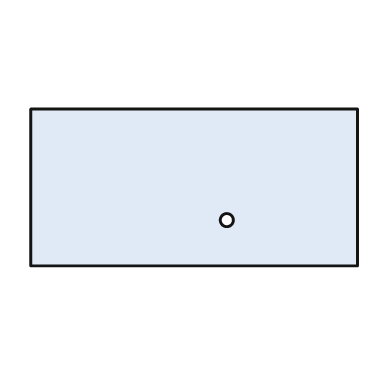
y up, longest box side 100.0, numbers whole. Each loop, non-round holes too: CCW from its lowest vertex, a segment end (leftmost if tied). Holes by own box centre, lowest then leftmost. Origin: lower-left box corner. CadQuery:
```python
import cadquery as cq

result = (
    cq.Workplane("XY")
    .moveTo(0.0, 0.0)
    .lineTo(100.0, 0.0)
    .lineTo(100.0, 48.0)
    .lineTo(0.0, 48.0)
    .close()
    .moveTo(60.0, 14.0)
    .circle(2.0)
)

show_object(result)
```